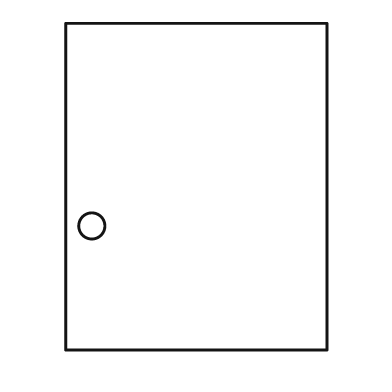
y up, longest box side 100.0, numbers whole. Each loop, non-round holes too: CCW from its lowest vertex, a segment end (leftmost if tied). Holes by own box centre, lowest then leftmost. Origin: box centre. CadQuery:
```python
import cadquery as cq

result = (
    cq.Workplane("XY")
    .moveTo(-40.0, -50.0)
    .lineTo(40.0, -50.0)
    .lineTo(40.0, 50.0)
    .lineTo(-40.0, 50.0)
    .close()
    .moveTo(-32.0, -12.0)
    .circle(4.0)
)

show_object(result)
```